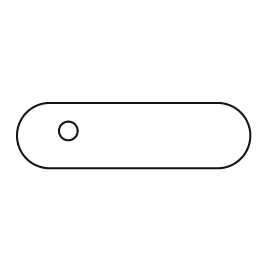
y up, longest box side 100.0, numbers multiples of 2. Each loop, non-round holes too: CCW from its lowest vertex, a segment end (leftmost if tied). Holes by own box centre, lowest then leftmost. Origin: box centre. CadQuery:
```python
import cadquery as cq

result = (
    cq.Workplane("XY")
    .moveTo(-36.0, -14.0)
    .lineTo(36.0, -14.0)
    .threePointArc((50.0, 0.0), (36.0, 14.0))
    .lineTo(-36.0, 14.0)
    .threePointArc((-50.0, 0.0), (-36.0, -14.0))
    .close()
    .moveTo(-28.0, 2.0)
    .circle(4.0)
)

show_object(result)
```